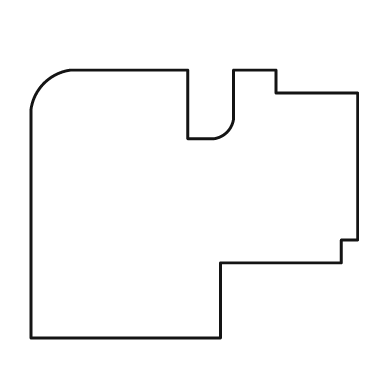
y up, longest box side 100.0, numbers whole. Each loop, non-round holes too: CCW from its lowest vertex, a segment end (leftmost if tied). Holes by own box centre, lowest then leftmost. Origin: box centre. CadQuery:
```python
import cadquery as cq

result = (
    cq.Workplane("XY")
    .moveTo(-50.0, -41.0)
    .lineTo(8.0, -41.0)
    .lineTo(8.0, -18.0)
    .lineTo(45.0, -18.0)
    .lineTo(45.0, -11.0)
    .lineTo(50.0, -11.0)
    .lineTo(50.0, 34.0)
    .lineTo(25.0, 34.0)
    .lineTo(25.0, 41.0)
    .lineTo(12.0, 41.0)
    .lineTo(12.0, 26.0)
    .threePointArc((10.0, 22.0), (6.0, 20.0))
    .lineTo(-2.0, 20.0)
    .lineTo(-2.0, 41.0)
    .lineTo(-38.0, 41.0)
    .threePointArc((-46.0, 37.0), (-50.0, 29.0))
    .close()
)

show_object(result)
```